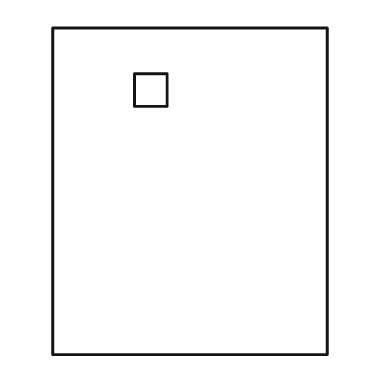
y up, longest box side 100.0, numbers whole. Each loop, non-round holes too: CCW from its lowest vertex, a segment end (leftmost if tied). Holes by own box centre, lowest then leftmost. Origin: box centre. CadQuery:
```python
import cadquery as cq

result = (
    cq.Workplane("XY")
    .moveTo(-42.0, -50.0)
    .lineTo(42.0, -50.0)
    .lineTo(42.0, 50.0)
    .lineTo(-42.0, 50.0)
    .close()
    .moveTo(-17.0, 26.0)
    .lineTo(-7.0, 26.0)
    .lineTo(-7.0, 36.0)
    .lineTo(-17.0, 36.0)
    .close()
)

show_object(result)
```